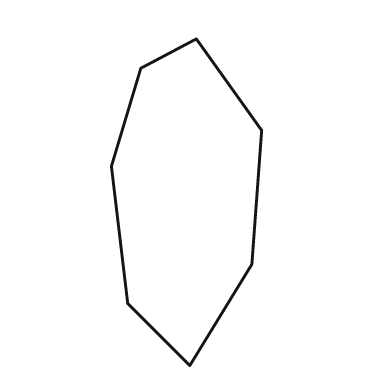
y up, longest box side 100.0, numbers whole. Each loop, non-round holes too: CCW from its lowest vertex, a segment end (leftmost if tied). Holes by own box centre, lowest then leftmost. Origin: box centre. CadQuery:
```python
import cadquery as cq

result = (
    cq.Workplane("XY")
    .moveTo(1.0, -50.0)
    .lineTo(20.0, -19.0)
    .lineTo(23.0, 22.0)
    .lineTo(3.0, 50.0)
    .lineTo(-14.0, 41.0)
    .lineTo(-23.0, 11.0)
    .lineTo(-18.0, -31.0)
    .close()
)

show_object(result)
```